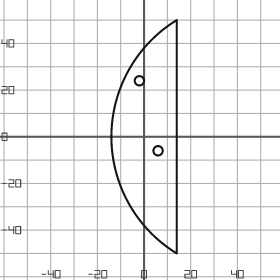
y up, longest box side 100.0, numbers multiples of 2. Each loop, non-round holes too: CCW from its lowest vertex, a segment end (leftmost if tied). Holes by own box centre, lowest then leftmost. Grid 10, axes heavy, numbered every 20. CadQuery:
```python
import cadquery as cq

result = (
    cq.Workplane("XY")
    .moveTo(14.0, -50.0)
    .lineTo(14.0, 50.0)
    .threePointArc((-14.0, 0.0), (14.0, -50.0))
    .close()
    .moveTo(6.0, -6.0)
    .circle(2.0)
    .moveTo(-2.0, 24.0)
    .circle(2.0)
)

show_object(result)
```